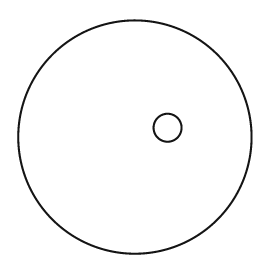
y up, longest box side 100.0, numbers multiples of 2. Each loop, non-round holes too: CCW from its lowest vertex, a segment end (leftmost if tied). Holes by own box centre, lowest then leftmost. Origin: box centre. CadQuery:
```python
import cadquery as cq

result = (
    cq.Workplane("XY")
    .moveTo(0.0, 0.0)
    .circle(50.0)
    .moveTo(14.0, 4.0)
    .circle(6.0)
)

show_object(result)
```